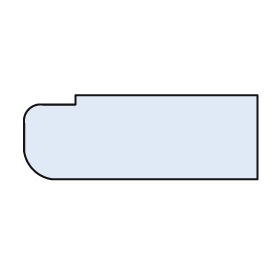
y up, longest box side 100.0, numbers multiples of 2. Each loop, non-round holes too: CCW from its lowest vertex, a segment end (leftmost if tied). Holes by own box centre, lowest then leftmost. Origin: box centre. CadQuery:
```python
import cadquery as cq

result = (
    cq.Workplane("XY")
    .moveTo(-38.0, -18.0)
    .lineTo(50.0, -18.0)
    .lineTo(50.0, 18.0)
    .lineTo(-28.0, 18.0)
    .lineTo(-28.0, 14.0)
    .lineTo(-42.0, 14.0)
    .threePointArc((-48.0, 12.0), (-50.0, 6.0))
    .lineTo(-50.0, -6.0)
    .threePointArc((-46.0, -14.0), (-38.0, -18.0))
    .close()
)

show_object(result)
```